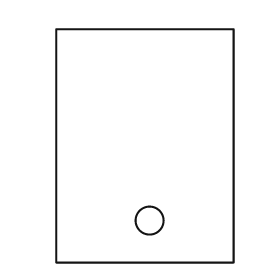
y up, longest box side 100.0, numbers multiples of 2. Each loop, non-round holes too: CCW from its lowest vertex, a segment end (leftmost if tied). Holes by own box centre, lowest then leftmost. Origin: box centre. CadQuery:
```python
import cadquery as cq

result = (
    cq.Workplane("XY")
    .moveTo(-38.0, -50.0)
    .lineTo(38.0, -50.0)
    .lineTo(38.0, 50.0)
    .lineTo(-38.0, 50.0)
    .close()
    .moveTo(2.0, -32.0)
    .circle(6.0)
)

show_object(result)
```